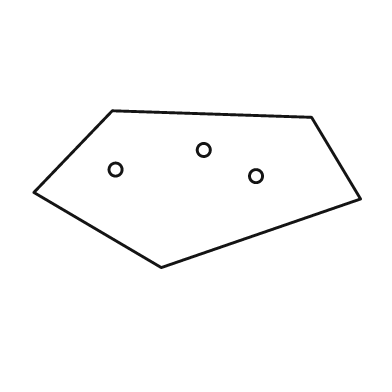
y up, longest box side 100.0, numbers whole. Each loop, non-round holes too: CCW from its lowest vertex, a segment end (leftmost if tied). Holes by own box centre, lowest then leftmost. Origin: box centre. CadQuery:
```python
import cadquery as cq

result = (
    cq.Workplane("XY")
    .moveTo(-11.0, -24.0)
    .lineTo(50.0, -3.0)
    .lineTo(35.0, 22.0)
    .lineTo(-26.0, 24.0)
    .lineTo(-50.0, -1.0)
    .close()
    .moveTo(18.0, 4.0)
    .circle(2.0)
    .moveTo(-25.0, 6.0)
    .circle(2.0)
    .moveTo(2.0, 12.0)
    .circle(2.0)
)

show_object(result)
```